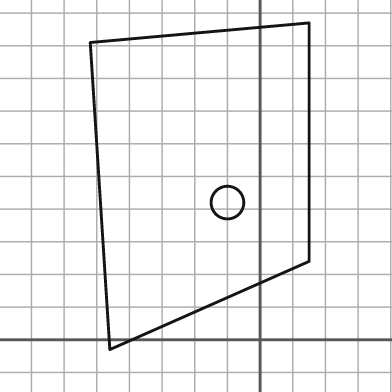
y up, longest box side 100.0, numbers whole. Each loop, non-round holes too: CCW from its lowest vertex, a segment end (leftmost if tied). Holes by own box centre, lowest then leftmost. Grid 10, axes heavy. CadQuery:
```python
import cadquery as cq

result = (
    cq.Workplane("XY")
    .moveTo(-46.0, -3.0)
    .lineTo(15.0, 24.0)
    .lineTo(15.0, 97.0)
    .lineTo(-52.0, 91.0)
    .close()
    .moveTo(-10.0, 42.0)
    .circle(5.0)
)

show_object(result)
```